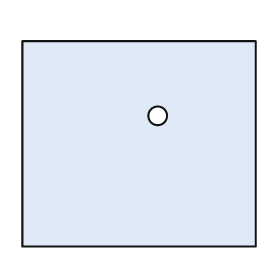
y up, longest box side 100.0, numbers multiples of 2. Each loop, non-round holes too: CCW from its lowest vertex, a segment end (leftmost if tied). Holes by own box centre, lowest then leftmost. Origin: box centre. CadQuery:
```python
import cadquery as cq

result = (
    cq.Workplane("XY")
    .moveTo(-50.0, -44.0)
    .lineTo(50.0, -44.0)
    .lineTo(50.0, 44.0)
    .lineTo(-50.0, 44.0)
    .close()
    .moveTo(8.0, 12.0)
    .circle(4.0)
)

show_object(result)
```